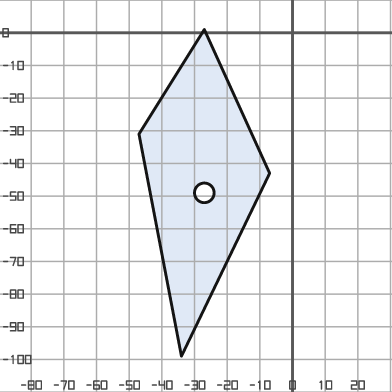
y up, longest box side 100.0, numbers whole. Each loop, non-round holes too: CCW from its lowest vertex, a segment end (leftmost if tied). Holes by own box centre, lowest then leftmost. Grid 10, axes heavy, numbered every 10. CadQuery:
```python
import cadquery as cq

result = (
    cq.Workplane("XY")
    .moveTo(-34.0, -99.0)
    .lineTo(-7.0, -43.0)
    .lineTo(-27.0, 1.0)
    .lineTo(-47.0, -31.0)
    .close()
    .moveTo(-27.0, -49.0)
    .circle(3.0)
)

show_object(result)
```